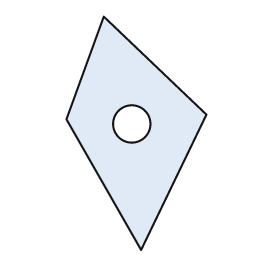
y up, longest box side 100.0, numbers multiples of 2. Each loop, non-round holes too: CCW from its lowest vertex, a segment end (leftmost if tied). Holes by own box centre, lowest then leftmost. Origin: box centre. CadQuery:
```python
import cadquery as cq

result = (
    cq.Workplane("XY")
    .moveTo(2.0, -50.0)
    .lineTo(30.0, 8.0)
    .lineTo(-14.0, 50.0)
    .lineTo(-30.0, 6.0)
    .close()
    .moveTo(-2.0, 4.0)
    .circle(8.0)
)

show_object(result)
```